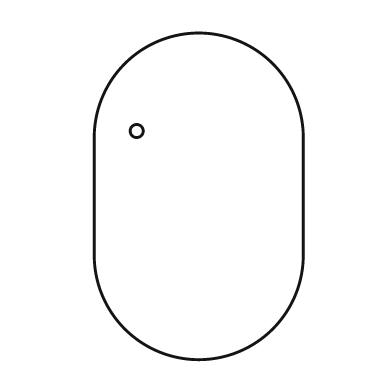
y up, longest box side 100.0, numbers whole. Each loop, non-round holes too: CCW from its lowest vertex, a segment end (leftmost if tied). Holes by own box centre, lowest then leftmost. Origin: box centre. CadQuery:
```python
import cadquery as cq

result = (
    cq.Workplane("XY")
    .moveTo(-32.0, -18.0)
    .threePointArc((0.0, -50.0), (32.0, -18.0))
    .lineTo(32.0, 18.0)
    .threePointArc((0.0, 50.0), (-32.0, 18.0))
    .close()
    .moveTo(-19.0, 20.0)
    .circle(2.0)
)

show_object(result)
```